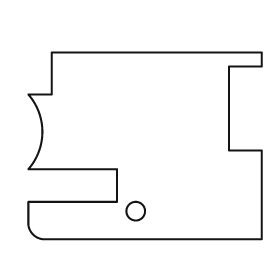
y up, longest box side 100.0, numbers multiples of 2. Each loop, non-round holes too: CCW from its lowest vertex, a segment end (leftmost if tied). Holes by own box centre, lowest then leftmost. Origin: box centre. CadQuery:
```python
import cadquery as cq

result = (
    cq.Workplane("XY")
    .moveTo(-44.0, -40.0)
    .lineTo(50.0, -40.0)
    .lineTo(50.0, -2.0)
    .lineTo(36.0, -2.0)
    .lineTo(36.0, 34.0)
    .lineTo(50.0, 34.0)
    .lineTo(50.0, 40.0)
    .lineTo(-40.0, 40.0)
    .lineTo(-40.0, 22.0)
    .lineTo(-50.0, 22.0)
    .threePointArc((-44.0, 6.0), (-50.0, -10.0))
    .lineTo(-12.0, -10.0)
    .lineTo(-12.0, -24.0)
    .lineTo(-50.0, -24.0)
    .lineTo(-50.0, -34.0)
    .threePointArc((-48.0, -38.0), (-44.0, -40.0))
    .close()
    .moveTo(-4.0, -28.0)
    .circle(4.0)
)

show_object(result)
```